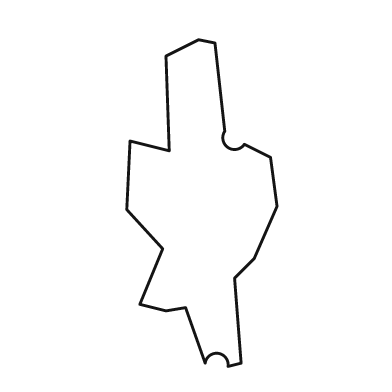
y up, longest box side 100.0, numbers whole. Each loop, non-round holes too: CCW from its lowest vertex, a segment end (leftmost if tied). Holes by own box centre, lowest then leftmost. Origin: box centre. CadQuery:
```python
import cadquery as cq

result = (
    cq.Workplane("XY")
    .moveTo(8.0, -50.0)
    .lineTo(12.0, -49.0)
    .lineTo(10.0, -23.0)
    .lineTo(16.0, -17.0)
    .lineTo(23.0, -1.0)
    .lineTo(21.0, 14.0)
    .lineTo(13.0, 18.0)
    .threePointArc((8.0, 17.0), (7.0, 22.0))
    .lineTo(4.0, 49.0)
    .lineTo(-1.0, 50.0)
    .lineTo(-11.0, 45.0)
    .lineTo(-10.0, 16.0)
    .lineTo(-22.0, 19.0)
    .lineTo(-23.0, -2.0)
    .lineTo(-12.0, -14.0)
    .lineTo(-19.0, -31.0)
    .lineTo(-11.0, -33.0)
    .lineTo(-5.0, -32.0)
    .lineTo(1.0, -49.0)
    .threePointArc((5.0, -46.0), (8.0, -50.0))
    .close()
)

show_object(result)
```